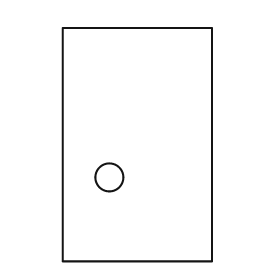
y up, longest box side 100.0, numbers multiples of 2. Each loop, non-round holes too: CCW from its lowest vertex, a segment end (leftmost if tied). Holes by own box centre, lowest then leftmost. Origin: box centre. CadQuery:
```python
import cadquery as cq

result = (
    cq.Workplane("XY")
    .moveTo(-32.0, -50.0)
    .lineTo(32.0, -50.0)
    .lineTo(32.0, 50.0)
    .lineTo(-32.0, 50.0)
    .close()
    .moveTo(-12.0, -14.0)
    .circle(6.0)
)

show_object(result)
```